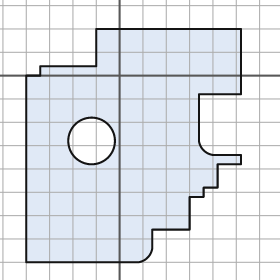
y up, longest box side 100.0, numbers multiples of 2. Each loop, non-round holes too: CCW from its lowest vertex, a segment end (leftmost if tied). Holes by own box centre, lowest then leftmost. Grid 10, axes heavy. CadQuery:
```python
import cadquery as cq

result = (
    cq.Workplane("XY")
    .moveTo(-40.0, -80.0)
    .lineTo(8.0, -80.0)
    .threePointArc((12.0, -78.0), (14.0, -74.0))
    .lineTo(14.0, -66.0)
    .lineTo(30.0, -66.0)
    .lineTo(30.0, -52.0)
    .lineTo(36.0, -52.0)
    .lineTo(36.0, -48.0)
    .lineTo(42.0, -48.0)
    .lineTo(42.0, -38.0)
    .lineTo(52.0, -38.0)
    .lineTo(52.0, -34.0)
    .lineTo(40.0, -34.0)
    .threePointArc((36.0, -32.0), (34.0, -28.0))
    .lineTo(34.0, -8.0)
    .lineTo(52.0, -8.0)
    .lineTo(52.0, 20.0)
    .lineTo(-10.0, 20.0)
    .lineTo(-10.0, 4.0)
    .lineTo(-34.0, 4.0)
    .lineTo(-34.0, 0.0)
    .lineTo(-40.0, 0.0)
    .close()
    .moveTo(-12.0, -28.0)
    .circle(10.0)
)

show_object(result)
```